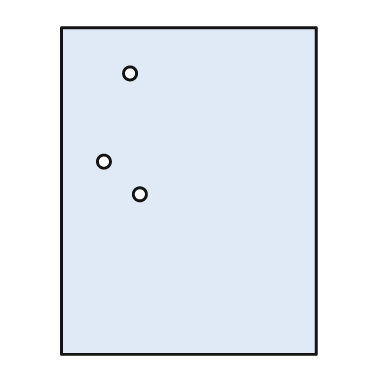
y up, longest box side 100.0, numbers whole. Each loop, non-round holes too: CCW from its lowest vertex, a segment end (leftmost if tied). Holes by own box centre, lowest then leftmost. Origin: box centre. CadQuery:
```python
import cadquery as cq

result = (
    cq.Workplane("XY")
    .moveTo(-39.0, -50.0)
    .lineTo(39.0, -50.0)
    .lineTo(39.0, 50.0)
    .lineTo(-39.0, 50.0)
    .close()
    .moveTo(-15.0, -1.0)
    .circle(2.0)
    .moveTo(-26.0, 9.0)
    .circle(2.0)
    .moveTo(-18.0, 36.0)
    .circle(2.0)
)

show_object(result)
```